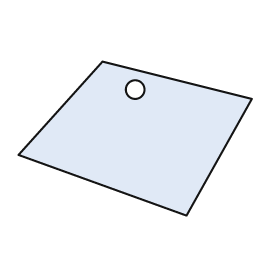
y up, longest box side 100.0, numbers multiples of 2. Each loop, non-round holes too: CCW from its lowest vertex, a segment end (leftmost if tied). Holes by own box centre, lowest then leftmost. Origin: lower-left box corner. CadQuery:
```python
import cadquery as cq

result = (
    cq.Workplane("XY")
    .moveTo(72.0, 0.0)
    .lineTo(100.0, 50.0)
    .lineTo(36.0, 66.0)
    .lineTo(0.0, 26.0)
    .close()
    .moveTo(50.0, 54.0)
    .circle(4.0)
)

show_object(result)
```